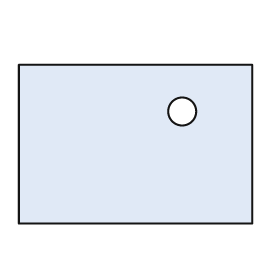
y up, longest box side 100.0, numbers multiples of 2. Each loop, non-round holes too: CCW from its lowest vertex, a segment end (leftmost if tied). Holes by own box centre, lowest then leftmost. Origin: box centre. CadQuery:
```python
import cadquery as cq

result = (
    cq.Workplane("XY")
    .moveTo(-50.0, -34.0)
    .lineTo(50.0, -34.0)
    .lineTo(50.0, 34.0)
    .lineTo(-50.0, 34.0)
    .close()
    .moveTo(20.0, 14.0)
    .circle(6.0)
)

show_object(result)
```